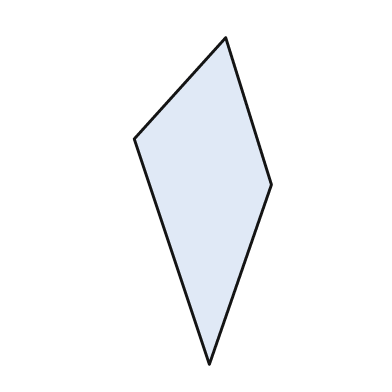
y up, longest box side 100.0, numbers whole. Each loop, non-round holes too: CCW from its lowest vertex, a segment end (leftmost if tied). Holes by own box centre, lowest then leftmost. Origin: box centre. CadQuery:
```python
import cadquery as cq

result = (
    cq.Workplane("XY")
    .moveTo(2.0, -50.0)
    .lineTo(21.0, 5.0)
    .lineTo(7.0, 50.0)
    .lineTo(-21.0, 19.0)
    .close()
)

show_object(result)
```